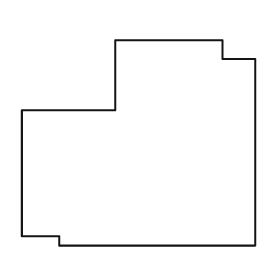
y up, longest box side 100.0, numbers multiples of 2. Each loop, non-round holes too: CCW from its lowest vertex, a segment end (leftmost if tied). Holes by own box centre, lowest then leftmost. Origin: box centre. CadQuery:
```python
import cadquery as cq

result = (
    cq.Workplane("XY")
    .moveTo(-34.0, -44.0)
    .lineTo(50.0, -44.0)
    .lineTo(50.0, 36.0)
    .lineTo(36.0, 36.0)
    .lineTo(36.0, 44.0)
    .lineTo(-10.0, 44.0)
    .lineTo(-10.0, 14.0)
    .lineTo(-50.0, 14.0)
    .lineTo(-50.0, -40.0)
    .lineTo(-34.0, -40.0)
    .close()
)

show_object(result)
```